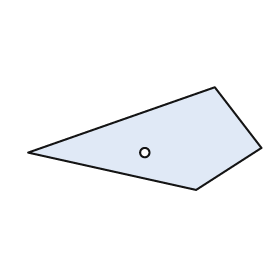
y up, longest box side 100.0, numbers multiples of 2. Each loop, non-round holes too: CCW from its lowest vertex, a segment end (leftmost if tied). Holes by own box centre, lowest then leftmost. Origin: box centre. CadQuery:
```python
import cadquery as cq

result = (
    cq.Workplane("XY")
    .moveTo(22.0, -22.0)
    .lineTo(50.0, -4.0)
    .lineTo(30.0, 22.0)
    .lineTo(-50.0, -6.0)
    .close()
    .moveTo(0.0, -6.0)
    .circle(2.0)
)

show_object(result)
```